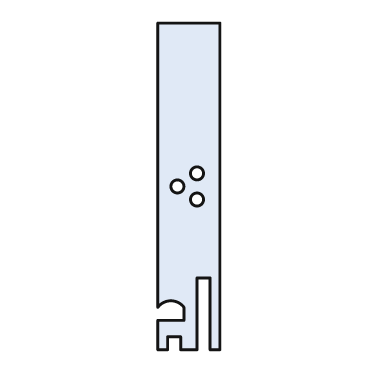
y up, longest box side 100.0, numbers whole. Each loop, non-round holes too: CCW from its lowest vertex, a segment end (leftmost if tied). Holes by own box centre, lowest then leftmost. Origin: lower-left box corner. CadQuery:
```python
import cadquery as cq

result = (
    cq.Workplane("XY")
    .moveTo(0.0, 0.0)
    .lineTo(3.0, 0.0)
    .lineTo(3.0, 4.0)
    .lineTo(7.0, 4.0)
    .lineTo(7.0, 0.0)
    .lineTo(12.0, 0.0)
    .lineTo(12.0, 22.0)
    .lineTo(16.0, 22.0)
    .lineTo(16.0, 0.0)
    .lineTo(19.0, 0.0)
    .lineTo(19.0, 100.0)
    .lineTo(0.0, 100.0)
    .lineTo(0.0, 13.0)
    .threePointArc((4.0, 15.0), (8.0, 13.0))
    .lineTo(8.0, 9.0)
    .lineTo(0.0, 9.0)
    .close()
    .moveTo(12.0, 46.0)
    .circle(2.0)
    .moveTo(6.0, 50.0)
    .circle(2.0)
    .moveTo(12.0, 54.0)
    .circle(2.0)
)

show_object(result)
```